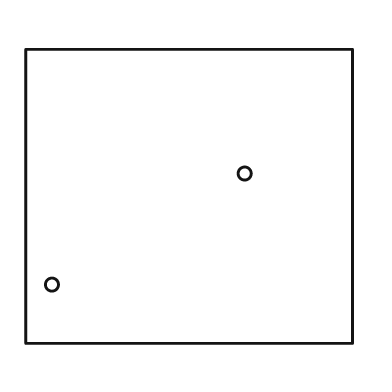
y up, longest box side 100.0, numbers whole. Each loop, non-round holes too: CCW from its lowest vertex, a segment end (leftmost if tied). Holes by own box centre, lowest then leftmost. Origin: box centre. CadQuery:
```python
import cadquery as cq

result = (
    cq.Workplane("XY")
    .moveTo(-50.0, -45.0)
    .lineTo(50.0, -45.0)
    .lineTo(50.0, 45.0)
    .lineTo(-50.0, 45.0)
    .close()
    .moveTo(-42.0, -27.0)
    .circle(2.0)
    .moveTo(17.0, 7.0)
    .circle(2.0)
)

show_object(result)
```